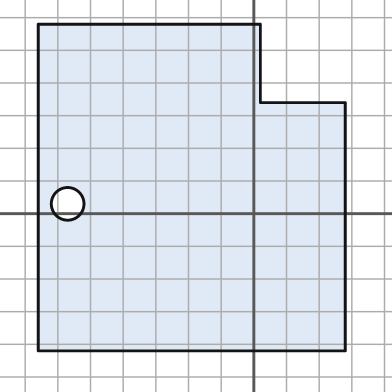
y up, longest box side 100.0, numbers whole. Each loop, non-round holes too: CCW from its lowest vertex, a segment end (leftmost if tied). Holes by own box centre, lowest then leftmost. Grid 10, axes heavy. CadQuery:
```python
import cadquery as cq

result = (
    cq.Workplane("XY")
    .moveTo(-66.0, -42.0)
    .lineTo(28.0, -42.0)
    .lineTo(28.0, 34.0)
    .lineTo(2.0, 34.0)
    .lineTo(2.0, 58.0)
    .lineTo(-66.0, 58.0)
    .close()
    .moveTo(-57.0, 3.0)
    .circle(5.0)
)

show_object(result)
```